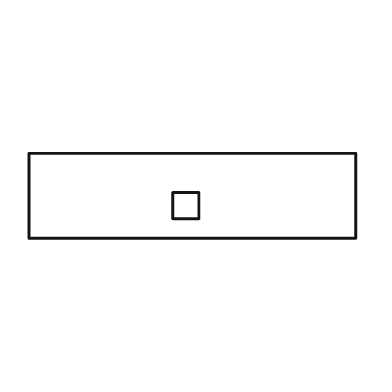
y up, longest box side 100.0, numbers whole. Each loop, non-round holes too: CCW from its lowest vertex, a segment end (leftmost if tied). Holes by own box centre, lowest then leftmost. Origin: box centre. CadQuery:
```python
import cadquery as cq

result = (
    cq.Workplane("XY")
    .moveTo(-50.0, -13.0)
    .lineTo(50.0, -13.0)
    .lineTo(50.0, 13.0)
    .lineTo(-50.0, 13.0)
    .close()
    .moveTo(-6.0, -7.0)
    .lineTo(2.0, -7.0)
    .lineTo(2.0, 1.0)
    .lineTo(-6.0, 1.0)
    .close()
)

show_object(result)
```